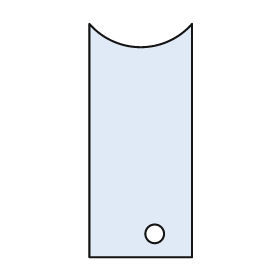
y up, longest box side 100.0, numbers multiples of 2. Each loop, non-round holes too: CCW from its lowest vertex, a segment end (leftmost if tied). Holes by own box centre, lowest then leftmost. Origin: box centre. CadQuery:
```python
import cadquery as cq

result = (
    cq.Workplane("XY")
    .moveTo(-22.0, -50.0)
    .lineTo(22.0, -50.0)
    .lineTo(22.0, 50.0)
    .threePointArc((0.0, 40.0), (-22.0, 50.0))
    .close()
    .moveTo(6.0, -40.0)
    .circle(4.0)
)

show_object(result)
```